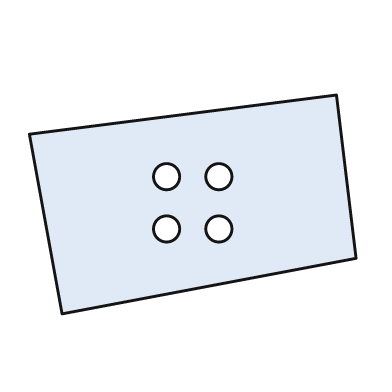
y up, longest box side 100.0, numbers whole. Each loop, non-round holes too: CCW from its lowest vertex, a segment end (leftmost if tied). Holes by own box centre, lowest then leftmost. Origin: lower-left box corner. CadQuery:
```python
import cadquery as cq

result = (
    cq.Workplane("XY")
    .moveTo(10.0, 0.0)
    .lineTo(100.0, 17.0)
    .lineTo(94.0, 67.0)
    .lineTo(0.0, 55.0)
    .close()
    .moveTo(42.0, 26.0)
    .circle(4.0)
    .moveTo(58.0, 26.0)
    .circle(4.0)
    .moveTo(42.0, 42.0)
    .circle(4.0)
    .moveTo(58.0, 42.0)
    .circle(4.0)
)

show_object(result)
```